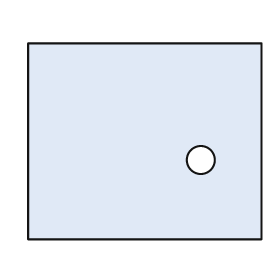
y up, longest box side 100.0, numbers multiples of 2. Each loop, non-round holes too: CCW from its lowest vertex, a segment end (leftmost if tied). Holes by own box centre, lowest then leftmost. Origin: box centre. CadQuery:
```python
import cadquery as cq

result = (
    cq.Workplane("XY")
    .moveTo(-50.0, -42.0)
    .lineTo(50.0, -42.0)
    .lineTo(50.0, 42.0)
    .lineTo(-50.0, 42.0)
    .close()
    .moveTo(24.0, -8.0)
    .circle(6.0)
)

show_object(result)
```